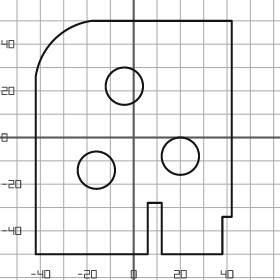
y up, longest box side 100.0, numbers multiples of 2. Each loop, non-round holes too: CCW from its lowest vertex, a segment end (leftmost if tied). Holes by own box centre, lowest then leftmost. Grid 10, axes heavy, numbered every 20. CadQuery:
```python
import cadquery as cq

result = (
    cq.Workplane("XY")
    .moveTo(-42.0, -50.0)
    .lineTo(6.0, -50.0)
    .lineTo(6.0, -28.0)
    .lineTo(12.0, -28.0)
    .lineTo(12.0, -50.0)
    .lineTo(38.0, -50.0)
    .lineTo(38.0, -34.0)
    .lineTo(42.0, -34.0)
    .lineTo(42.0, 50.0)
    .lineTo(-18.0, 50.0)
    .threePointArc((-34.0, 42.0), (-42.0, 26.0))
    .close()
    .moveTo(-16.0, -14.0)
    .circle(8.0)
    .moveTo(20.0, -8.0)
    .circle(8.0)
    .moveTo(-4.0, 22.0)
    .circle(8.0)
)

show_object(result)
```